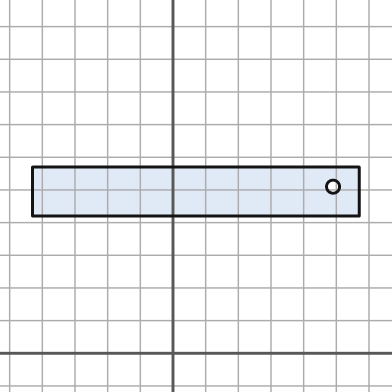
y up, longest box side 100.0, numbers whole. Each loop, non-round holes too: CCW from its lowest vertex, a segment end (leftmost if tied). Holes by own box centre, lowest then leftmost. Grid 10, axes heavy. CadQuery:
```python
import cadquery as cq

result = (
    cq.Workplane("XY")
    .moveTo(-43.0, 42.0)
    .lineTo(57.0, 42.0)
    .lineTo(57.0, 57.0)
    .lineTo(-43.0, 57.0)
    .close()
    .moveTo(49.0, 51.0)
    .circle(2.0)
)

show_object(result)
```